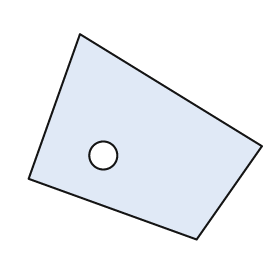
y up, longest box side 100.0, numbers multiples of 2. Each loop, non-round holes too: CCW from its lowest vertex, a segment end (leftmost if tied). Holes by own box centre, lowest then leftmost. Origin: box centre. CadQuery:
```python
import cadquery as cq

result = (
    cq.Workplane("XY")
    .moveTo(22.0, -44.0)
    .lineTo(50.0, -4.0)
    .lineTo(-28.0, 44.0)
    .lineTo(-50.0, -18.0)
    .close()
    .moveTo(-18.0, -8.0)
    .circle(6.0)
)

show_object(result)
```